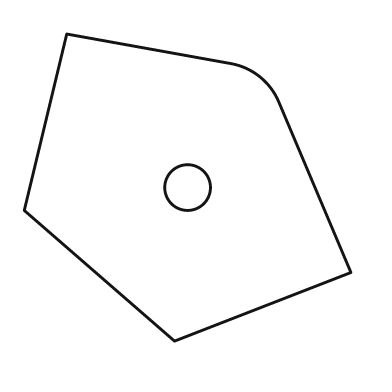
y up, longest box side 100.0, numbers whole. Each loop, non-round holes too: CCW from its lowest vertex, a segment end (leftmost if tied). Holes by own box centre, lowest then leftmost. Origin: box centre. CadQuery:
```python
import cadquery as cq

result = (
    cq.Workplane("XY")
    .moveTo(-4.0, -47.0)
    .lineTo(50.0, -26.0)
    .lineTo(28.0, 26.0)
    .threePointArc((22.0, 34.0), (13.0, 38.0))
    .lineTo(-37.0, 47.0)
    .lineTo(-50.0, -7.0)
    .close()
    .moveTo(0.0, 0.0)
    .circle(7.0)
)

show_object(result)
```